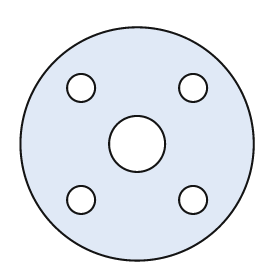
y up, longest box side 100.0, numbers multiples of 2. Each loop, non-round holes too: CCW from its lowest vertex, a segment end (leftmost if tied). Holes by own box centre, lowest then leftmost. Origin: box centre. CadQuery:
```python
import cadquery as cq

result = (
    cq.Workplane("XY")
    .moveTo(0.0, 0.0)
    .circle(50.0)
    .moveTo(-24.0, -24.0)
    .circle(6.0)
    .moveTo(24.0, -24.0)
    .circle(6.0)
    .moveTo(0.0, 0.0)
    .circle(12.0)
    .moveTo(-24.0, 24.0)
    .circle(6.0)
    .moveTo(24.0, 24.0)
    .circle(6.0)
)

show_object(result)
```